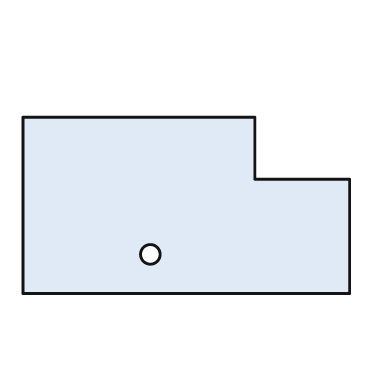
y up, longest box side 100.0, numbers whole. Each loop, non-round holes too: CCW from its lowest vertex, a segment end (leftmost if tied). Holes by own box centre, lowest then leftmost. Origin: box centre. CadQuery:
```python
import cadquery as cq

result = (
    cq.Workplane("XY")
    .moveTo(-50.0, -27.0)
    .lineTo(50.0, -27.0)
    .lineTo(50.0, 8.0)
    .lineTo(21.0, 8.0)
    .lineTo(21.0, 27.0)
    .lineTo(-50.0, 27.0)
    .close()
    .moveTo(-11.0, -15.0)
    .circle(3.0)
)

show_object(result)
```